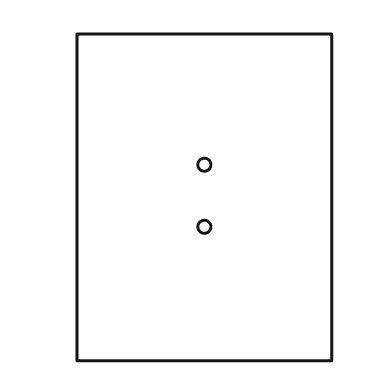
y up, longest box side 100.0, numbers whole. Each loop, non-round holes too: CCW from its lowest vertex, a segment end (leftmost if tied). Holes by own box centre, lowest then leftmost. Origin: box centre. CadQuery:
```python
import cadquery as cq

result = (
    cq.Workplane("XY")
    .moveTo(-39.0, -50.0)
    .lineTo(39.0, -50.0)
    .lineTo(39.0, 50.0)
    .lineTo(-39.0, 50.0)
    .close()
    .moveTo(0.0, -9.0)
    .circle(2.0)
    .moveTo(0.0, 10.0)
    .circle(2.0)
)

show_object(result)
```